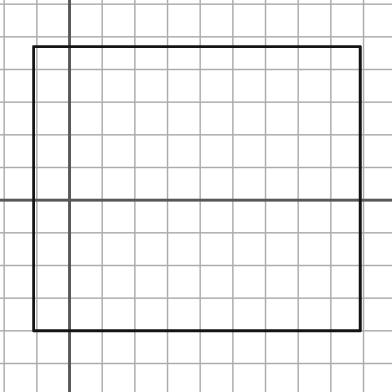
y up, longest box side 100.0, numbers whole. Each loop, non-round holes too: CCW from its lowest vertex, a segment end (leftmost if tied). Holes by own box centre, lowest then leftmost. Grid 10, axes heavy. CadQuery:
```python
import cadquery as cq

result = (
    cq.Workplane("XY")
    .moveTo(-11.0, -40.0)
    .lineTo(89.0, -40.0)
    .lineTo(89.0, 47.0)
    .lineTo(-11.0, 47.0)
    .close()
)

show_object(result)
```